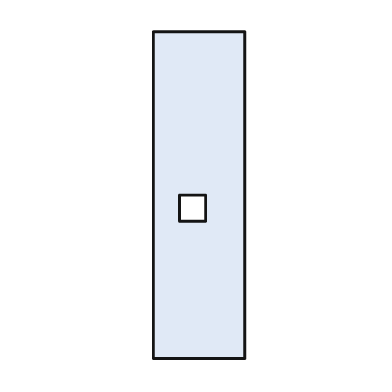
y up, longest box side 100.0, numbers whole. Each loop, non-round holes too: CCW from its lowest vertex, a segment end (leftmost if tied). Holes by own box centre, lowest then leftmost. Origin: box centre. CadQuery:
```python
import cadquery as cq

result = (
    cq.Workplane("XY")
    .moveTo(-14.0, -50.0)
    .lineTo(14.0, -50.0)
    .lineTo(14.0, 50.0)
    .lineTo(-14.0, 50.0)
    .close()
    .moveTo(-6.0, -8.0)
    .lineTo(2.0, -8.0)
    .lineTo(2.0, 0.0)
    .lineTo(-6.0, 0.0)
    .close()
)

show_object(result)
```